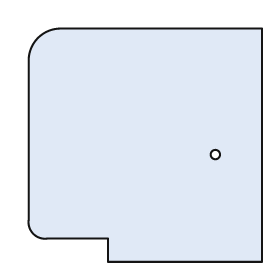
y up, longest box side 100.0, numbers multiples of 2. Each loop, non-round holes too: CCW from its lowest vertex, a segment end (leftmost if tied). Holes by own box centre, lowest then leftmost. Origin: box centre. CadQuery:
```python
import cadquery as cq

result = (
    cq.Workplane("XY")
    .moveTo(-16.0, -50.0)
    .lineTo(50.0, -50.0)
    .lineTo(50.0, 50.0)
    .lineTo(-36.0, 50.0)
    .threePointArc((-46.0, 46.0), (-50.0, 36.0))
    .lineTo(-50.0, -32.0)
    .threePointArc((-48.0, -38.0), (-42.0, -40.0))
    .lineTo(-16.0, -40.0)
    .close()
    .moveTo(30.0, -4.0)
    .circle(2.0)
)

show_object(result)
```